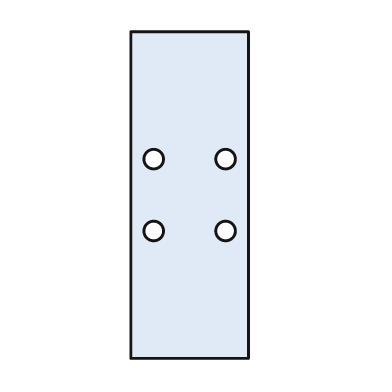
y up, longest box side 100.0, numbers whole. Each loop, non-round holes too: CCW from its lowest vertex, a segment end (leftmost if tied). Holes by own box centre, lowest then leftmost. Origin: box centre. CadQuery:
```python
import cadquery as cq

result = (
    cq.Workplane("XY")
    .moveTo(-18.0, -50.0)
    .lineTo(18.0, -50.0)
    .lineTo(18.0, 50.0)
    .lineTo(-18.0, 50.0)
    .close()
    .moveTo(-11.0, -11.0)
    .circle(3.0)
    .moveTo(11.0, -11.0)
    .circle(3.0)
    .moveTo(-11.0, 11.0)
    .circle(3.0)
    .moveTo(11.0, 11.0)
    .circle(3.0)
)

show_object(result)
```